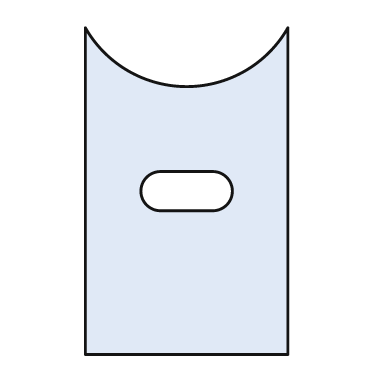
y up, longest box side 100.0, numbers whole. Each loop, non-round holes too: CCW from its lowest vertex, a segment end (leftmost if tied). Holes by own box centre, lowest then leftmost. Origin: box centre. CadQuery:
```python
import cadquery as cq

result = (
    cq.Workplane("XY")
    .moveTo(-31.0, -50.0)
    .lineTo(31.0, -50.0)
    .lineTo(31.0, 50.0)
    .threePointArc((0.0, 32.0), (-31.0, 50.0))
    .close()
    .moveTo(-8.0, -6.0)
    .lineTo(8.0, -6.0)
    .threePointArc((14.0, 0.0), (8.0, 6.0))
    .lineTo(-8.0, 6.0)
    .threePointArc((-14.0, 0.0), (-8.0, -6.0))
    .close()
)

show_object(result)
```